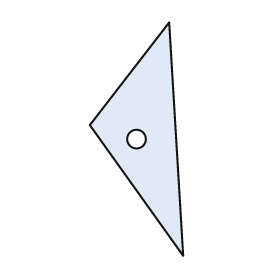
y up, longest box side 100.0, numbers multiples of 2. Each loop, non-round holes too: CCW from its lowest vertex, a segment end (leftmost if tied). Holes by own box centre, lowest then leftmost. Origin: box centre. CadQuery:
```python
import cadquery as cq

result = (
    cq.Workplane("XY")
    .moveTo(20.0, -50.0)
    .lineTo(14.0, 50.0)
    .lineTo(-20.0, 6.0)
    .close()
    .moveTo(0.0, 0.0)
    .circle(4.0)
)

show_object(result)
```